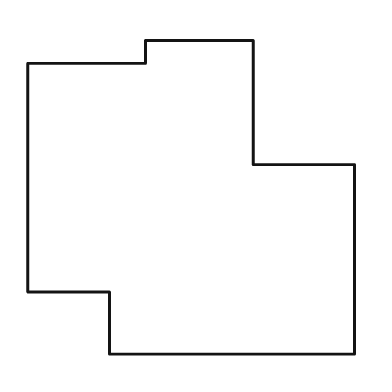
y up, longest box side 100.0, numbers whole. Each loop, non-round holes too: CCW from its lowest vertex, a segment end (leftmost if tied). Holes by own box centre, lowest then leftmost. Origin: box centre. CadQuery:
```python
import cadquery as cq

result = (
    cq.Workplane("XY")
    .moveTo(-25.0, -48.0)
    .lineTo(50.0, -48.0)
    .lineTo(50.0, 10.0)
    .lineTo(19.0, 10.0)
    .lineTo(19.0, 48.0)
    .lineTo(-14.0, 48.0)
    .lineTo(-14.0, 41.0)
    .lineTo(-50.0, 41.0)
    .lineTo(-50.0, -29.0)
    .lineTo(-25.0, -29.0)
    .close()
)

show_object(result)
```